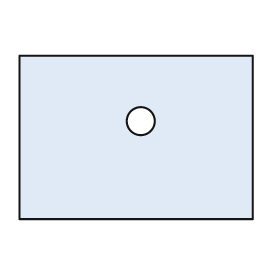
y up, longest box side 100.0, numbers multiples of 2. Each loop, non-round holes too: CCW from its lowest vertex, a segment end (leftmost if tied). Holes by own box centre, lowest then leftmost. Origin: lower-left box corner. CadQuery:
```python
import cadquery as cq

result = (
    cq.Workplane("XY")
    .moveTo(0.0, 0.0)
    .lineTo(100.0, 0.0)
    .lineTo(100.0, 70.0)
    .lineTo(0.0, 70.0)
    .close()
    .moveTo(52.0, 42.0)
    .circle(6.0)
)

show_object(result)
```